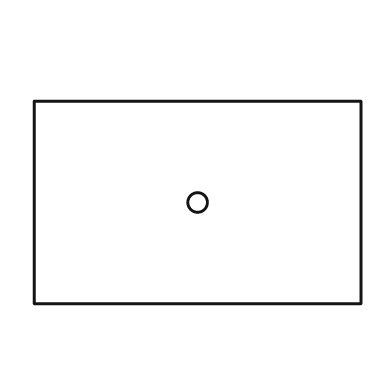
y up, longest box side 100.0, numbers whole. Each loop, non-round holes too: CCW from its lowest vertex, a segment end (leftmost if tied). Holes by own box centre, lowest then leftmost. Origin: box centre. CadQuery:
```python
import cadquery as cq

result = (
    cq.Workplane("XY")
    .moveTo(-50.0, -31.0)
    .lineTo(50.0, -31.0)
    .lineTo(50.0, 31.0)
    .lineTo(-50.0, 31.0)
    .close()
    .moveTo(0.0, 0.0)
    .circle(3.0)
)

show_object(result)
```